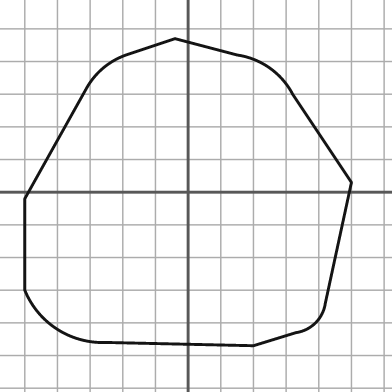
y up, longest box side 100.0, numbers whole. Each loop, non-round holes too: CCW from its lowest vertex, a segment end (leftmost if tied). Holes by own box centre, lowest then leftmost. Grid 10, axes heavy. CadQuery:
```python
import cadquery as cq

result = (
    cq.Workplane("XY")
    .moveTo(20.0, -47.0)
    .lineTo(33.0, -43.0)
    .threePointArc((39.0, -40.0), (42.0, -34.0))
    .lineTo(50.0, 3.0)
    .lineTo(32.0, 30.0)
    .threePointArc((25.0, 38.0), (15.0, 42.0))
    .lineTo(-4.0, 47.0)
    .lineTo(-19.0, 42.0)
    .threePointArc((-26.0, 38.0), (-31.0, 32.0))
    .lineTo(-50.0, -2.0)
    .lineTo(-50.0, -30.0)
    .threePointArc((-40.0, -42.0), (-25.0, -46.0))
    .close()
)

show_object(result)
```